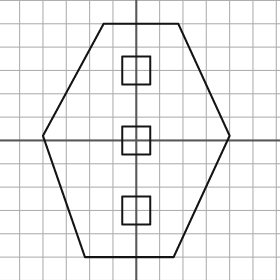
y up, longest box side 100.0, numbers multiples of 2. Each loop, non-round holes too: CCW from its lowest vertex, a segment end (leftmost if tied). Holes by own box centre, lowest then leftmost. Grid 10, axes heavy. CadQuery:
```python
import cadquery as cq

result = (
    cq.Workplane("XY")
    .moveTo(-22.0, -50.0)
    .lineTo(16.0, -50.0)
    .lineTo(40.0, 2.0)
    .lineTo(18.0, 50.0)
    .lineTo(-14.0, 50.0)
    .lineTo(-40.0, 2.0)
    .close()
    .moveTo(-6.0, -36.0)
    .lineTo(6.0, -36.0)
    .lineTo(6.0, -24.0)
    .lineTo(-6.0, -24.0)
    .close()
    .moveTo(-6.0, -6.0)
    .lineTo(6.0, -6.0)
    .lineTo(6.0, 6.0)
    .lineTo(-6.0, 6.0)
    .close()
    .moveTo(-6.0, 24.0)
    .lineTo(6.0, 24.0)
    .lineTo(6.0, 36.0)
    .lineTo(-6.0, 36.0)
    .close()
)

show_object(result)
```